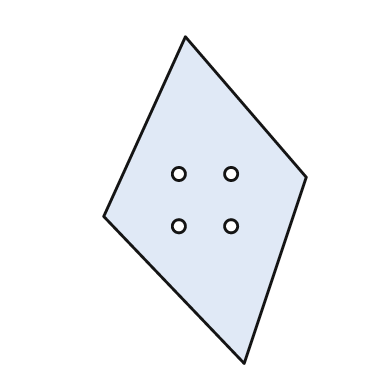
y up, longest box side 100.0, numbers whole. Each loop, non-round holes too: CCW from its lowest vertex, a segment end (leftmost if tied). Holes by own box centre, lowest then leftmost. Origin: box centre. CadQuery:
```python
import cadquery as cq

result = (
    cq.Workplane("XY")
    .moveTo(12.0, -50.0)
    .lineTo(31.0, 7.0)
    .lineTo(-6.0, 50.0)
    .lineTo(-31.0, -5.0)
    .close()
    .moveTo(-8.0, -8.0)
    .circle(2.0)
    .moveTo(8.0, -8.0)
    .circle(2.0)
    .moveTo(-8.0, 8.0)
    .circle(2.0)
    .moveTo(8.0, 8.0)
    .circle(2.0)
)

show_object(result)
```